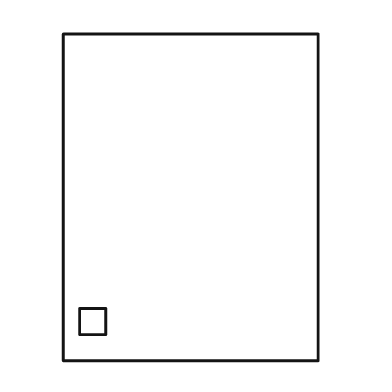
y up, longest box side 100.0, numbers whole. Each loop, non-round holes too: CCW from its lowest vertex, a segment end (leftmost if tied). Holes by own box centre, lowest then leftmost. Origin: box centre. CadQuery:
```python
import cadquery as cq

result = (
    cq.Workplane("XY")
    .moveTo(-39.0, -50.0)
    .lineTo(39.0, -50.0)
    .lineTo(39.0, 50.0)
    .lineTo(-39.0, 50.0)
    .close()
    .moveTo(-34.0, -42.0)
    .lineTo(-26.0, -42.0)
    .lineTo(-26.0, -34.0)
    .lineTo(-34.0, -34.0)
    .close()
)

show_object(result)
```